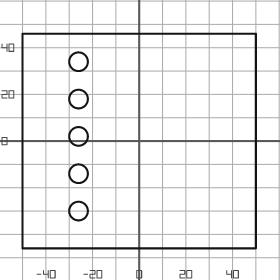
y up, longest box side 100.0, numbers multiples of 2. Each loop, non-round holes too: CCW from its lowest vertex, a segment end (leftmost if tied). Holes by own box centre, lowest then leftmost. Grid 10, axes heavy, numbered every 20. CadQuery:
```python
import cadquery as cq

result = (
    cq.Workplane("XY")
    .moveTo(-50.0, -46.0)
    .lineTo(50.0, -46.0)
    .lineTo(50.0, 46.0)
    .lineTo(-50.0, 46.0)
    .close()
    .moveTo(-26.0, -30.0)
    .circle(4.0)
    .moveTo(-26.0, -14.0)
    .circle(4.0)
    .moveTo(-26.0, 2.0)
    .circle(4.0)
    .moveTo(-26.0, 18.0)
    .circle(4.0)
    .moveTo(-26.0, 34.0)
    .circle(4.0)
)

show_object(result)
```